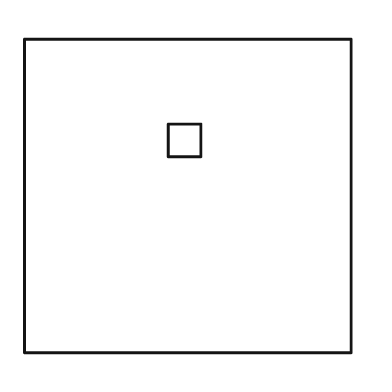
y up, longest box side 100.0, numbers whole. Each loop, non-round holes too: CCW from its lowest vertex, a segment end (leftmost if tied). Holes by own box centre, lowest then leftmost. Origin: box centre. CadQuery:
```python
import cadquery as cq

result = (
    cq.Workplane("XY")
    .moveTo(-50.0, -48.0)
    .lineTo(50.0, -48.0)
    .lineTo(50.0, 48.0)
    .lineTo(-50.0, 48.0)
    .close()
    .moveTo(-6.0, 12.0)
    .lineTo(4.0, 12.0)
    .lineTo(4.0, 22.0)
    .lineTo(-6.0, 22.0)
    .close()
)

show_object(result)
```